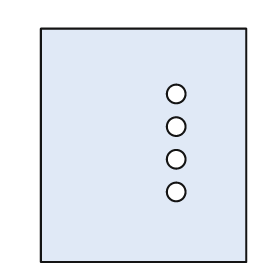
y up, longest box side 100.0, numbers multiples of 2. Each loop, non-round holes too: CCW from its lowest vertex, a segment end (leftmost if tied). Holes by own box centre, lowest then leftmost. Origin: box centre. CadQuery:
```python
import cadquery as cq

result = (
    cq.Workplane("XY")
    .moveTo(-44.0, -50.0)
    .lineTo(44.0, -50.0)
    .lineTo(44.0, 50.0)
    .lineTo(-44.0, 50.0)
    .close()
    .moveTo(14.0, -20.0)
    .circle(4.0)
    .moveTo(14.0, -6.0)
    .circle(4.0)
    .moveTo(14.0, 8.0)
    .circle(4.0)
    .moveTo(14.0, 22.0)
    .circle(4.0)
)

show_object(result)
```